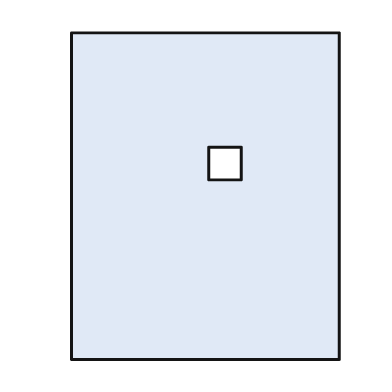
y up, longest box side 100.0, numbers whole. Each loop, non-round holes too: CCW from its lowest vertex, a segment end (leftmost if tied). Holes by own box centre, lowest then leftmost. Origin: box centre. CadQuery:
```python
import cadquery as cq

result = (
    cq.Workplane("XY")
    .moveTo(-41.0, -50.0)
    .lineTo(41.0, -50.0)
    .lineTo(41.0, 50.0)
    .lineTo(-41.0, 50.0)
    .close()
    .moveTo(1.0, 5.0)
    .lineTo(11.0, 5.0)
    .lineTo(11.0, 15.0)
    .lineTo(1.0, 15.0)
    .close()
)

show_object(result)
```